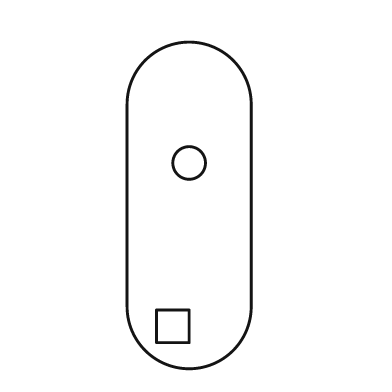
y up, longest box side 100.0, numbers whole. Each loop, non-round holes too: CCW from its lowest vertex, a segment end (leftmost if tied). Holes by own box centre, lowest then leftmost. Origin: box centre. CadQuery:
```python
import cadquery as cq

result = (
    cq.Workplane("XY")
    .moveTo(-19.0, -31.0)
    .threePointArc((0.0, -50.0), (19.0, -31.0))
    .lineTo(19.0, 31.0)
    .threePointArc((0.0, 50.0), (-19.0, 31.0))
    .close()
    .moveTo(-10.0, -42.0)
    .lineTo(0.0, -42.0)
    .lineTo(0.0, -32.0)
    .lineTo(-10.0, -32.0)
    .close()
    .moveTo(0.0, 13.0)
    .circle(5.0)
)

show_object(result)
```